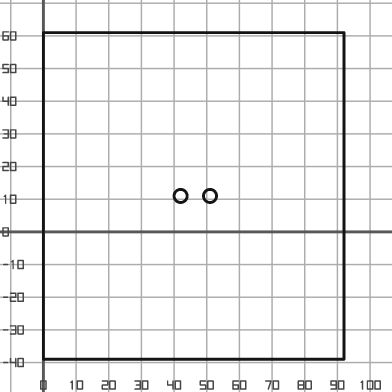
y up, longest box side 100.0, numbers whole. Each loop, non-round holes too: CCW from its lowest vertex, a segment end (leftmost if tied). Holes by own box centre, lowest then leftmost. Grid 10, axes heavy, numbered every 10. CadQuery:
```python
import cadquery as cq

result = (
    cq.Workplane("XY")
    .moveTo(0.0, -39.0)
    .lineTo(92.0, -39.0)
    .lineTo(92.0, 61.0)
    .lineTo(0.0, 61.0)
    .close()
    .moveTo(42.0, 11.0)
    .circle(2.0)
    .moveTo(51.0, 11.0)
    .circle(2.0)
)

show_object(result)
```